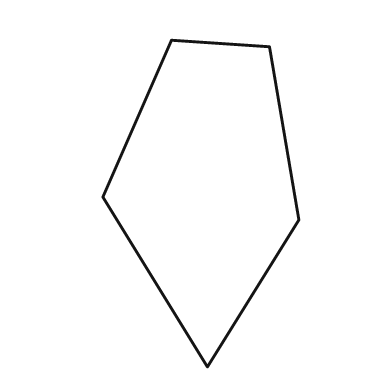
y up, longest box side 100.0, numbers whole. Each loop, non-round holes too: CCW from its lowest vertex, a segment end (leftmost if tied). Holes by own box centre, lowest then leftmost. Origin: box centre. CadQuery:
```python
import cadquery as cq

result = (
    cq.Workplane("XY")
    .moveTo(2.0, -50.0)
    .lineTo(30.0, -5.0)
    .lineTo(21.0, 48.0)
    .lineTo(-9.0, 50.0)
    .lineTo(-30.0, 2.0)
    .close()
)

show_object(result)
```